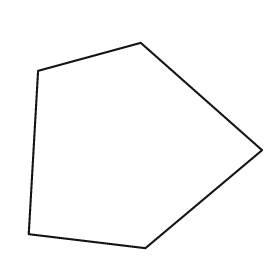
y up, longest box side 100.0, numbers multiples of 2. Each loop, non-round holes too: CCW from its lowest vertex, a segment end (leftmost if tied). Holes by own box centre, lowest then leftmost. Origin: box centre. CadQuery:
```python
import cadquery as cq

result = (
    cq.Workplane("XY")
    .moveTo(0.0, -44.0)
    .lineTo(50.0, -2.0)
    .lineTo(-2.0, 44.0)
    .lineTo(-46.0, 32.0)
    .lineTo(-50.0, -38.0)
    .close()
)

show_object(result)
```